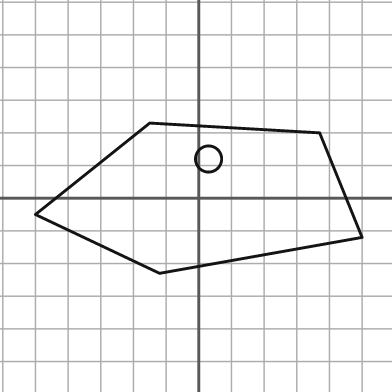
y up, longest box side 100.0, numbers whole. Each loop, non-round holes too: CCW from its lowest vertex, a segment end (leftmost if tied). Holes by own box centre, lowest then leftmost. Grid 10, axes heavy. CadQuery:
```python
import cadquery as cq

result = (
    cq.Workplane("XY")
    .moveTo(-12.0, -23.0)
    .lineTo(50.0, -12.0)
    .lineTo(37.0, 20.0)
    .lineTo(-15.0, 23.0)
    .lineTo(-50.0, -5.0)
    .close()
    .moveTo(3.0, 12.0)
    .circle(4.0)
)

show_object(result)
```